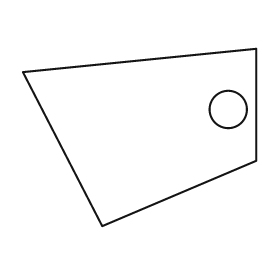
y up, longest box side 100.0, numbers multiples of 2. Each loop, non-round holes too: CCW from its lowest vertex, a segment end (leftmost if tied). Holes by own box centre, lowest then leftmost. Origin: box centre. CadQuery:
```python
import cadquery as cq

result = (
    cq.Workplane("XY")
    .moveTo(-16.0, -38.0)
    .lineTo(50.0, -10.0)
    .lineTo(50.0, 38.0)
    .lineTo(-50.0, 28.0)
    .close()
    .moveTo(38.0, 12.0)
    .circle(8.0)
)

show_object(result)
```